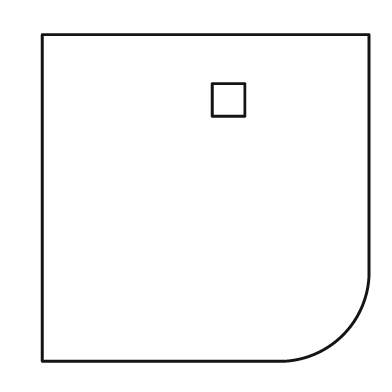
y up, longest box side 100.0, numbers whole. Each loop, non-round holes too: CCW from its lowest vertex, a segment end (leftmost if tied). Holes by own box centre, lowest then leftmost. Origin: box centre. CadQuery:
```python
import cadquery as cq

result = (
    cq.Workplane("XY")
    .moveTo(-50.0, -50.0)
    .lineTo(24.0, -50.0)
    .threePointArc((42.0, -42.0), (50.0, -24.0))
    .lineTo(50.0, 50.0)
    .lineTo(-50.0, 50.0)
    .close()
    .moveTo(2.0, 25.0)
    .lineTo(12.0, 25.0)
    .lineTo(12.0, 35.0)
    .lineTo(2.0, 35.0)
    .close()
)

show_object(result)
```